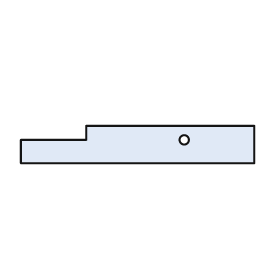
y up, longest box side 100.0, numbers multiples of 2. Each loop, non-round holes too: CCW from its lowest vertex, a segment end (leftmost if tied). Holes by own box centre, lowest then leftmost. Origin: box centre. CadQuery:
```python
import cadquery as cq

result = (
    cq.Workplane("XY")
    .moveTo(-50.0, -8.0)
    .lineTo(50.0, -8.0)
    .lineTo(50.0, 8.0)
    .lineTo(-22.0, 8.0)
    .lineTo(-22.0, 2.0)
    .lineTo(-50.0, 2.0)
    .close()
    .moveTo(20.0, 2.0)
    .circle(2.0)
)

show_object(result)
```